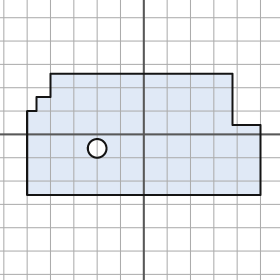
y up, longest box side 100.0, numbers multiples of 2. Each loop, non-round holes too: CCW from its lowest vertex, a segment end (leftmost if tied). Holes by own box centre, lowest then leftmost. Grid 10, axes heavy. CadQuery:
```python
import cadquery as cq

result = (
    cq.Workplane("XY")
    .moveTo(-50.0, -26.0)
    .lineTo(50.0, -26.0)
    .lineTo(50.0, 4.0)
    .lineTo(38.0, 4.0)
    .lineTo(38.0, 26.0)
    .lineTo(-40.0, 26.0)
    .lineTo(-40.0, 16.0)
    .lineTo(-46.0, 16.0)
    .lineTo(-46.0, 10.0)
    .lineTo(-50.0, 10.0)
    .close()
    .moveTo(-20.0, -6.0)
    .circle(4.0)
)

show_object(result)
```